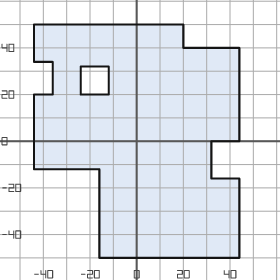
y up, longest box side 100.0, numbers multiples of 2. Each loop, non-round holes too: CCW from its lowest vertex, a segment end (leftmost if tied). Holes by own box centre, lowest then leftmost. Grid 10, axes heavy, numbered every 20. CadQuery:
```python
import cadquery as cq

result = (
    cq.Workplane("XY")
    .moveTo(-16.0, -50.0)
    .lineTo(44.0, -50.0)
    .lineTo(44.0, -16.0)
    .lineTo(32.0, -16.0)
    .lineTo(32.0, 0.0)
    .lineTo(44.0, 0.0)
    .lineTo(44.0, 40.0)
    .lineTo(20.0, 40.0)
    .lineTo(20.0, 50.0)
    .lineTo(-44.0, 50.0)
    .lineTo(-44.0, 34.0)
    .lineTo(-36.0, 34.0)
    .lineTo(-36.0, 20.0)
    .lineTo(-44.0, 20.0)
    .lineTo(-44.0, -12.0)
    .lineTo(-16.0, -12.0)
    .close()
    .moveTo(-24.0, 20.0)
    .lineTo(-12.0, 20.0)
    .lineTo(-12.0, 32.0)
    .lineTo(-24.0, 32.0)
    .close()
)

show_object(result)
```